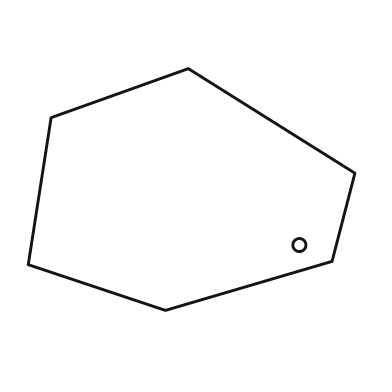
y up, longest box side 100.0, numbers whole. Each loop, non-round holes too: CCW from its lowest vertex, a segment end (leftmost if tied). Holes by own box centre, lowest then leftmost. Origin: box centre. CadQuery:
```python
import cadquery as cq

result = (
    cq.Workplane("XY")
    .moveTo(-8.0, -37.0)
    .lineTo(43.0, -22.0)
    .lineTo(50.0, 5.0)
    .lineTo(-1.0, 37.0)
    .lineTo(-43.0, 22.0)
    .lineTo(-50.0, -23.0)
    .close()
    .moveTo(33.0, -17.0)
    .circle(2.0)
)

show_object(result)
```